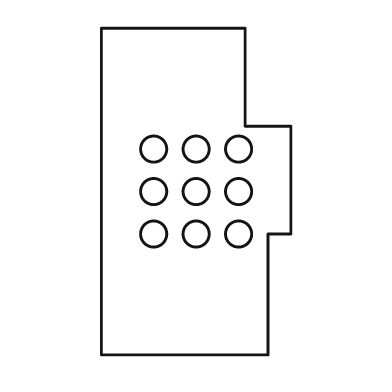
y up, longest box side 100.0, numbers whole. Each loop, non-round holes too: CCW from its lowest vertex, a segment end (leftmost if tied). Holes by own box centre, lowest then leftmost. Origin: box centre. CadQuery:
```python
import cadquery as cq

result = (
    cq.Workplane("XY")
    .moveTo(-29.0, -50.0)
    .lineTo(22.0, -50.0)
    .lineTo(22.0, -13.0)
    .lineTo(29.0, -13.0)
    .lineTo(29.0, 20.0)
    .lineTo(15.0, 20.0)
    .lineTo(15.0, 50.0)
    .lineTo(-29.0, 50.0)
    .close()
    .moveTo(-13.0, -13.0)
    .circle(4.0)
    .moveTo(0.0, -13.0)
    .circle(4.0)
    .moveTo(13.0, -13.0)
    .circle(4.0)
    .moveTo(-13.0, 0.0)
    .circle(4.0)
    .moveTo(0.0, 0.0)
    .circle(4.0)
    .moveTo(13.0, 0.0)
    .circle(4.0)
    .moveTo(-13.0, 13.0)
    .circle(4.0)
    .moveTo(0.0, 13.0)
    .circle(4.0)
    .moveTo(13.0, 13.0)
    .circle(4.0)
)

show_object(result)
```